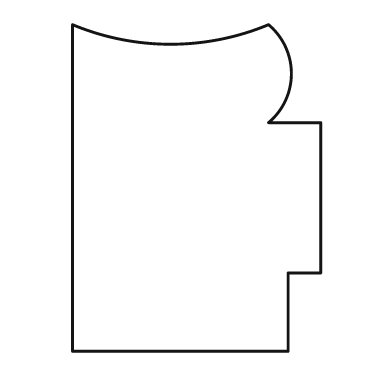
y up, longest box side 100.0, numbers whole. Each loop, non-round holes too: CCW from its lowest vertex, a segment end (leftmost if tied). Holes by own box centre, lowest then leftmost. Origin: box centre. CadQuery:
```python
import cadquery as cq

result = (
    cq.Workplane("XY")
    .moveTo(-38.0, -50.0)
    .lineTo(28.0, -50.0)
    .lineTo(28.0, -26.0)
    .lineTo(38.0, -26.0)
    .lineTo(38.0, 20.0)
    .lineTo(22.0, 20.0)
    .threePointArc((29.0, 35.0), (22.0, 50.0))
    .threePointArc((-8.0, 44.0), (-38.0, 50.0))
    .close()
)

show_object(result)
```